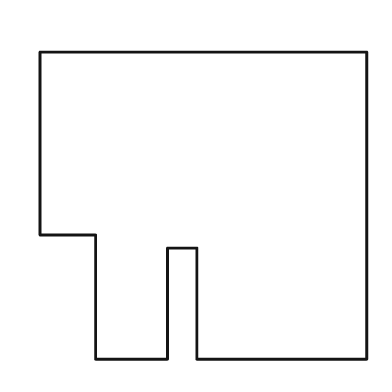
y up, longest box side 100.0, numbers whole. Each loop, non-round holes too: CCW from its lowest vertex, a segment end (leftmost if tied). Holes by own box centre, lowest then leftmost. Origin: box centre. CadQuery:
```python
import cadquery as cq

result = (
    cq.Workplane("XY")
    .moveTo(-33.0, -47.0)
    .lineTo(-11.0, -47.0)
    .lineTo(-11.0, -13.0)
    .lineTo(-2.0, -13.0)
    .lineTo(-2.0, -47.0)
    .lineTo(50.0, -47.0)
    .lineTo(50.0, 47.0)
    .lineTo(-50.0, 47.0)
    .lineTo(-50.0, -9.0)
    .lineTo(-33.0, -9.0)
    .close()
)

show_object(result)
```